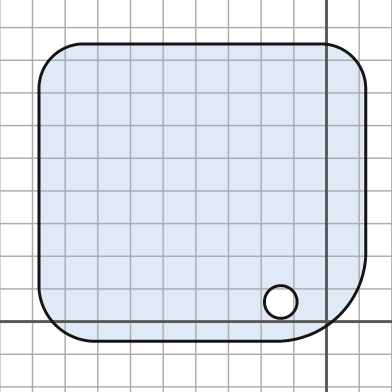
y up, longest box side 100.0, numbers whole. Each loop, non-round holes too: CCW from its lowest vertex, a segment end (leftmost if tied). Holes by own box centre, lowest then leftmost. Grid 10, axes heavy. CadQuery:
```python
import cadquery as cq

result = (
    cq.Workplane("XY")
    .moveTo(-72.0, -6.0)
    .lineTo(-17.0, -6.0)
    .threePointArc((4.0, 2.0), (12.0, 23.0))
    .lineTo(12.0, 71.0)
    .threePointArc((8.0, 81.0), (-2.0, 85.0))
    .lineTo(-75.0, 85.0)
    .threePointArc((-84.0, 81.0), (-88.0, 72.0))
    .lineTo(-88.0, 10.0)
    .threePointArc((-83.0, -1.0), (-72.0, -6.0))
    .close()
    .moveTo(-14.0, 6.0)
    .circle(5.0)
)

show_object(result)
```